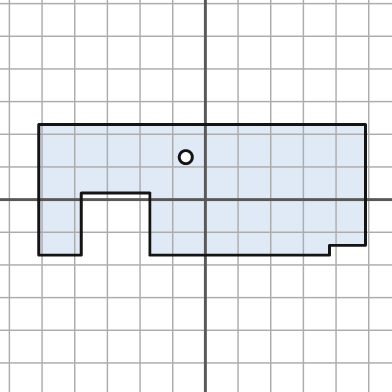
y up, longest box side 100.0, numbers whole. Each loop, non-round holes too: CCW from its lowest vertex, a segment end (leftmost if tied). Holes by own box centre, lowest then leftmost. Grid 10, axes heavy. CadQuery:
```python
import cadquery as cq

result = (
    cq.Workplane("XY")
    .moveTo(-51.0, -17.0)
    .lineTo(-38.0, -17.0)
    .lineTo(-38.0, 2.0)
    .lineTo(-17.0, 2.0)
    .lineTo(-17.0, -17.0)
    .lineTo(38.0, -17.0)
    .lineTo(38.0, -14.0)
    .lineTo(49.0, -14.0)
    .lineTo(49.0, 23.0)
    .lineTo(-51.0, 23.0)
    .close()
    .moveTo(-6.0, 13.0)
    .circle(2.0)
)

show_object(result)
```